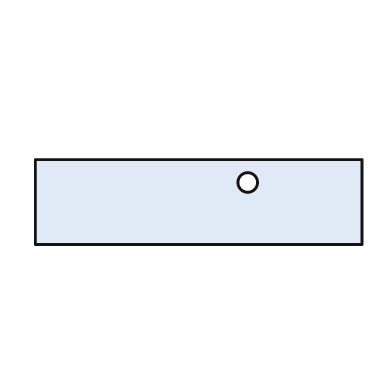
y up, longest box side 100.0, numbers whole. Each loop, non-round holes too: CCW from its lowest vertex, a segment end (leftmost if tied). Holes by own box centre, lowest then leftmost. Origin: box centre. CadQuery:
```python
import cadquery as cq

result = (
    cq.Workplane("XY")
    .moveTo(-50.0, -13.0)
    .lineTo(50.0, -13.0)
    .lineTo(50.0, 13.0)
    .lineTo(-50.0, 13.0)
    .close()
    .moveTo(15.0, 6.0)
    .circle(3.0)
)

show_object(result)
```